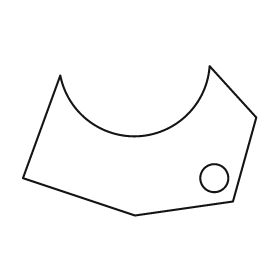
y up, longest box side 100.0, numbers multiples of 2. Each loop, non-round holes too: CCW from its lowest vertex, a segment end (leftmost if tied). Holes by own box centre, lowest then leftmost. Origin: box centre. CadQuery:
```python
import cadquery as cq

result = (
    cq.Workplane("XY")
    .moveTo(-2.0, -32.0)
    .lineTo(40.0, -26.0)
    .lineTo(50.0, 10.0)
    .lineTo(30.0, 32.0)
    .threePointArc((0.0, 2.0), (-34.0, 28.0))
    .lineTo(-50.0, -16.0)
    .close()
    .moveTo(32.0, -16.0)
    .circle(6.0)
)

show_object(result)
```